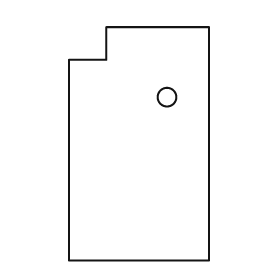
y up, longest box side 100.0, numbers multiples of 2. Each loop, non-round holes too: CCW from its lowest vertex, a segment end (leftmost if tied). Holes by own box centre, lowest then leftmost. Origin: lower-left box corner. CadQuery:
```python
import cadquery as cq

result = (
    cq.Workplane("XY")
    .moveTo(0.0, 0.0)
    .lineTo(60.0, 0.0)
    .lineTo(60.0, 100.0)
    .lineTo(16.0, 100.0)
    .lineTo(16.0, 86.0)
    .lineTo(0.0, 86.0)
    .close()
    .moveTo(42.0, 70.0)
    .circle(4.0)
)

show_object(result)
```